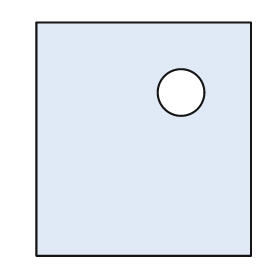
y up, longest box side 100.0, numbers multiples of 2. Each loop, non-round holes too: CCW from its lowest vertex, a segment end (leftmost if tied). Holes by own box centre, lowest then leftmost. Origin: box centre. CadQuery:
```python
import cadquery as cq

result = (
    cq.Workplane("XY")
    .moveTo(-46.0, -50.0)
    .lineTo(46.0, -50.0)
    .lineTo(46.0, 50.0)
    .lineTo(-46.0, 50.0)
    .close()
    .moveTo(16.0, 20.0)
    .circle(10.0)
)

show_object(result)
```